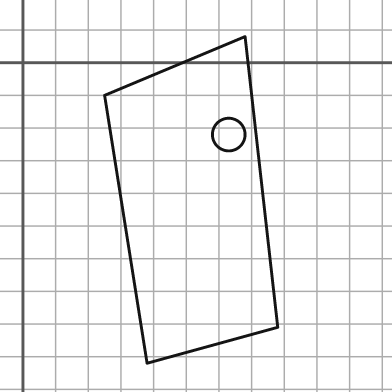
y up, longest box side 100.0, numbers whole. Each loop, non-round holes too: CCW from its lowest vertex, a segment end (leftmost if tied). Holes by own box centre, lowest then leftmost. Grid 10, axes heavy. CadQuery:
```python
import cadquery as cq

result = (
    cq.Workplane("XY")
    .moveTo(38.0, -92.0)
    .lineTo(78.0, -81.0)
    .lineTo(68.0, 8.0)
    .lineTo(25.0, -10.0)
    .close()
    .moveTo(63.0, -22.0)
    .circle(5.0)
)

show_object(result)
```